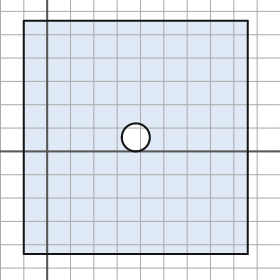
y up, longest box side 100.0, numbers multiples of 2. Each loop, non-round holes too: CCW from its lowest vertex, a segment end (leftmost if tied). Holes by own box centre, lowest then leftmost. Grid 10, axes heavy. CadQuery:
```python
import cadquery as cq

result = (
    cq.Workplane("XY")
    .moveTo(-10.0, -44.0)
    .lineTo(86.0, -44.0)
    .lineTo(86.0, 56.0)
    .lineTo(-10.0, 56.0)
    .close()
    .moveTo(38.0, 6.0)
    .circle(6.0)
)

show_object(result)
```